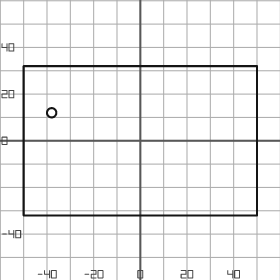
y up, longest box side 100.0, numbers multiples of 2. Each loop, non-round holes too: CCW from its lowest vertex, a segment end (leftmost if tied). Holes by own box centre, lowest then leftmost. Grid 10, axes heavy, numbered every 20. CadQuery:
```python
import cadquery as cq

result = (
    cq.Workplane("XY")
    .moveTo(-50.0, -32.0)
    .lineTo(50.0, -32.0)
    .lineTo(50.0, 32.0)
    .lineTo(-50.0, 32.0)
    .close()
    .moveTo(-38.0, 12.0)
    .circle(2.0)
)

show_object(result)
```